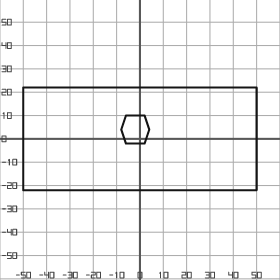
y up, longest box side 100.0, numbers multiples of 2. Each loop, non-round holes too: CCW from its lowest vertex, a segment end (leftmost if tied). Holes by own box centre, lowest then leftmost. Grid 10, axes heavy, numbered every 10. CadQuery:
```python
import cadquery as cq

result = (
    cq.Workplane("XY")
    .moveTo(-50.0, -22.0)
    .lineTo(50.0, -22.0)
    .lineTo(50.0, 22.0)
    .lineTo(-50.0, 22.0)
    .close()
    .moveTo(-6.0, -2.0)
    .lineTo(2.0, -2.0)
    .lineTo(4.0, 4.0)
    .lineTo(2.0, 10.0)
    .lineTo(-6.0, 10.0)
    .lineTo(-8.0, 4.0)
    .close()
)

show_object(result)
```